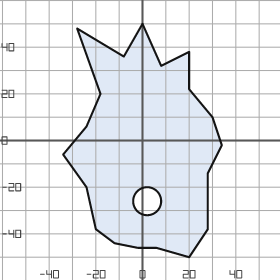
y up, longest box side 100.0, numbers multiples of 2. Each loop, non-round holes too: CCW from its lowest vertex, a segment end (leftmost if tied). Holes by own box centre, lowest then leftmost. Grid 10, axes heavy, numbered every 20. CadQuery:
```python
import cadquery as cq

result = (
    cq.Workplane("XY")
    .moveTo(20.0, -50.0)
    .lineTo(28.0, -38.0)
    .lineTo(28.0, -14.0)
    .lineTo(34.0, -2.0)
    .lineTo(30.0, 10.0)
    .lineTo(20.0, 22.0)
    .lineTo(20.0, 38.0)
    .lineTo(8.0, 32.0)
    .lineTo(0.0, 50.0)
    .lineTo(-8.0, 36.0)
    .lineTo(-28.0, 48.0)
    .lineTo(-18.0, 20.0)
    .lineTo(-24.0, 6.0)
    .lineTo(-34.0, -6.0)
    .lineTo(-24.0, -20.0)
    .lineTo(-20.0, -38.0)
    .lineTo(-12.0, -44.0)
    .lineTo(-2.0, -46.0)
    .lineTo(6.0, -46.0)
    .close()
    .moveTo(2.0, -26.0)
    .circle(6.0)
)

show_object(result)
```